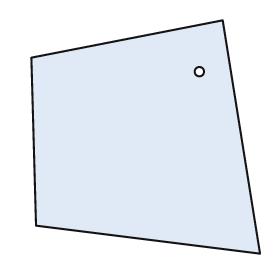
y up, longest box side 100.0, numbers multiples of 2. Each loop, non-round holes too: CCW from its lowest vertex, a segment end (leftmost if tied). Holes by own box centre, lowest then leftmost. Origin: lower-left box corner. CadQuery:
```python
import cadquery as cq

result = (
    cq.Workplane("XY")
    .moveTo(98.0, 0.0)
    .lineTo(82.0, 100.0)
    .lineTo(0.0, 84.0)
    .lineTo(2.0, 12.0)
    .close()
    .moveTo(72.0, 78.0)
    .circle(2.0)
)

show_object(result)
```